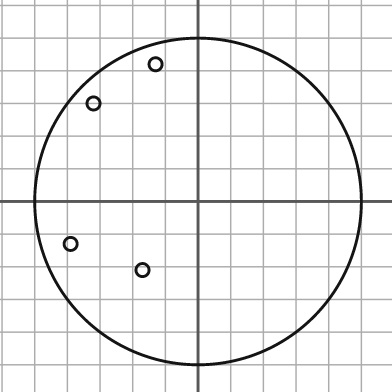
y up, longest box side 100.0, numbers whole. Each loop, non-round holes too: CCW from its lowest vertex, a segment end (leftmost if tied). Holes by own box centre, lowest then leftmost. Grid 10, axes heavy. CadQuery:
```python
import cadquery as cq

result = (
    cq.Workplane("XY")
    .moveTo(0.0, 0.0)
    .circle(50.0)
    .moveTo(-17.0, -21.0)
    .circle(2.0)
    .moveTo(-39.0, -13.0)
    .circle(2.0)
    .moveTo(-32.0, 30.0)
    .circle(2.0)
    .moveTo(-13.0, 42.0)
    .circle(2.0)
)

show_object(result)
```